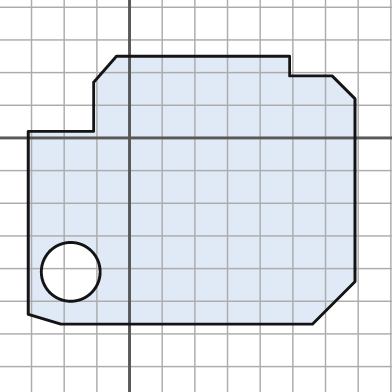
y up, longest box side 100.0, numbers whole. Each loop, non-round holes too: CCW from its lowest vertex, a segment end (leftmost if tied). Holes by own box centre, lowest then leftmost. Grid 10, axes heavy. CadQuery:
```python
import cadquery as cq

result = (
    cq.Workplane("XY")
    .moveTo(-21.0, -57.0)
    .lineTo(56.0, -57.0)
    .lineTo(69.0, -44.0)
    .lineTo(69.0, 12.0)
    .lineTo(62.0, 19.0)
    .lineTo(49.0, 19.0)
    .lineTo(49.0, 25.0)
    .lineTo(-4.0, 25.0)
    .lineTo(-11.0, 17.0)
    .lineTo(-11.0, 2.0)
    .lineTo(-31.0, 2.0)
    .lineTo(-31.0, -54.0)
    .close()
    .moveTo(-18.0, -41.0)
    .circle(9.0)
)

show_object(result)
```